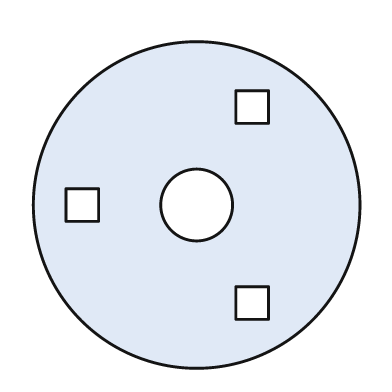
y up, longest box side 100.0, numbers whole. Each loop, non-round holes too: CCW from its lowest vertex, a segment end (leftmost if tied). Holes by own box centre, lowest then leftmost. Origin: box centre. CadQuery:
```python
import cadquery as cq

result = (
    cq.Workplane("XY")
    .moveTo(0.0, 0.0)
    .circle(50.0)
    .moveTo(12.0, -35.0)
    .lineTo(22.0, -35.0)
    .lineTo(22.0, -25.0)
    .lineTo(12.0, -25.0)
    .close()
    .moveTo(-40.0, -5.0)
    .lineTo(-30.0, -5.0)
    .lineTo(-30.0, 5.0)
    .lineTo(-40.0, 5.0)
    .close()
    .moveTo(0.0, 0.0)
    .circle(11.0)
    .moveTo(12.0, 25.0)
    .lineTo(22.0, 25.0)
    .lineTo(22.0, 35.0)
    .lineTo(12.0, 35.0)
    .close()
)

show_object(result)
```